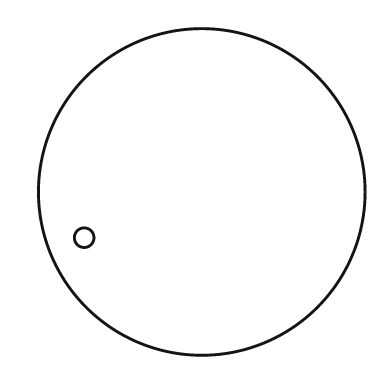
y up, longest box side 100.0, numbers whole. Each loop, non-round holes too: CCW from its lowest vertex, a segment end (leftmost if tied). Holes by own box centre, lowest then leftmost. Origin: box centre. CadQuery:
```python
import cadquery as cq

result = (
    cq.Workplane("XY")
    .moveTo(0.0, 0.0)
    .circle(50.0)
    .moveTo(-36.0, -14.0)
    .circle(3.0)
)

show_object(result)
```